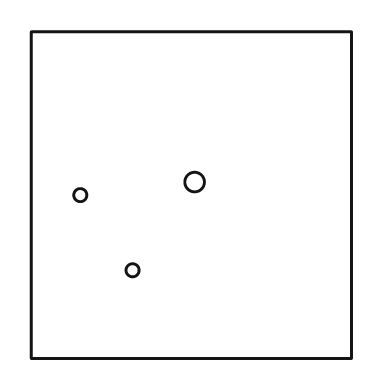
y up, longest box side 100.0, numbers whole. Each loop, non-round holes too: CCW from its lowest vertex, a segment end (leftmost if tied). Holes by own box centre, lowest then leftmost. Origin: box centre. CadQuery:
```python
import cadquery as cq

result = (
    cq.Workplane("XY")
    .moveTo(-49.0, -50.0)
    .lineTo(49.0, -50.0)
    .lineTo(49.0, 50.0)
    .lineTo(-49.0, 50.0)
    .close()
    .moveTo(-18.0, -23.0)
    .circle(2.0)
    .moveTo(-34.0, 0.0)
    .circle(2.0)
    .moveTo(1.0, 4.0)
    .circle(3.0)
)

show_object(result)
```